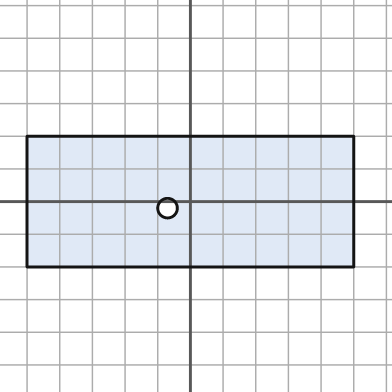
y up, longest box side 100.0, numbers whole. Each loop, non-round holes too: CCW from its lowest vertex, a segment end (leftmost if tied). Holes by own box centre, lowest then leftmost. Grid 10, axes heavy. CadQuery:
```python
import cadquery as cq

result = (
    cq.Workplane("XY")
    .moveTo(-50.0, -20.0)
    .lineTo(50.0, -20.0)
    .lineTo(50.0, 20.0)
    .lineTo(-50.0, 20.0)
    .close()
    .moveTo(-7.0, -2.0)
    .circle(3.0)
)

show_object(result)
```